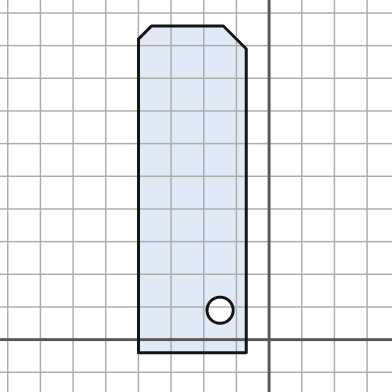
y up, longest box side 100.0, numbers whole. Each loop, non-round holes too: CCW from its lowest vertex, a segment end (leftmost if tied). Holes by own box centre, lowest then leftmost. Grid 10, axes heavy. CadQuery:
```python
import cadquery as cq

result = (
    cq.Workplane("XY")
    .moveTo(-40.0, -4.0)
    .lineTo(-7.0, -4.0)
    .lineTo(-7.0, 89.0)
    .lineTo(-14.0, 96.0)
    .lineTo(-36.0, 96.0)
    .lineTo(-40.0, 92.0)
    .close()
    .moveTo(-15.0, 9.0)
    .circle(4.0)
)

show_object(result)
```